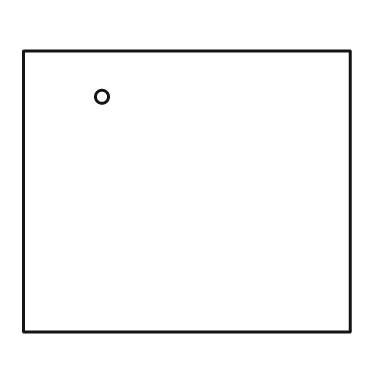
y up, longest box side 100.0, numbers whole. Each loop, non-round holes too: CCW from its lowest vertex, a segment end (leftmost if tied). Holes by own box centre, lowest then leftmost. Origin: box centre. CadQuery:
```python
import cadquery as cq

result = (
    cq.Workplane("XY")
    .moveTo(-50.0, -43.0)
    .lineTo(50.0, -43.0)
    .lineTo(50.0, 43.0)
    .lineTo(-50.0, 43.0)
    .close()
    .moveTo(-26.0, 29.0)
    .circle(2.0)
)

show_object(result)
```